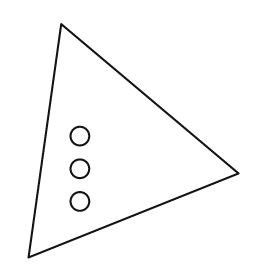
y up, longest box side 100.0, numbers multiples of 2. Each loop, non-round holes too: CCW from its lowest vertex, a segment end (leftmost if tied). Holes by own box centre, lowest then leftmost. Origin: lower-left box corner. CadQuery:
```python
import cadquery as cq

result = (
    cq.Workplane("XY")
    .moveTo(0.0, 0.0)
    .lineTo(90.0, 36.0)
    .lineTo(14.0, 100.0)
    .close()
    .moveTo(22.0, 24.0)
    .circle(4.0)
    .moveTo(22.0, 38.0)
    .circle(4.0)
    .moveTo(22.0, 52.0)
    .circle(4.0)
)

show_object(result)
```